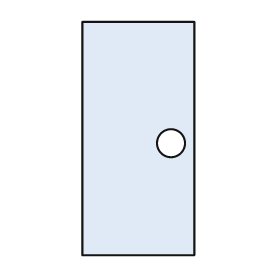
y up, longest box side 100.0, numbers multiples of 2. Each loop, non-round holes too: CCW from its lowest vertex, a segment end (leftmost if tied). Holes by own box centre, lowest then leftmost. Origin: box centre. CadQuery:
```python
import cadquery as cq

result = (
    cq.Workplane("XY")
    .moveTo(-24.0, -50.0)
    .lineTo(24.0, -50.0)
    .lineTo(24.0, 50.0)
    .lineTo(-24.0, 50.0)
    .close()
    .moveTo(14.0, -2.0)
    .circle(6.0)
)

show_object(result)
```